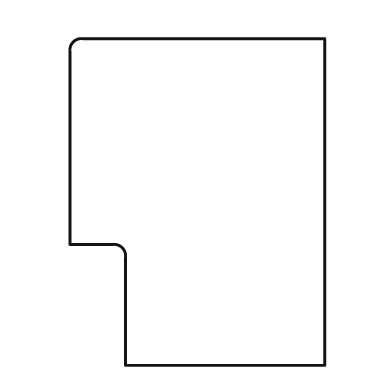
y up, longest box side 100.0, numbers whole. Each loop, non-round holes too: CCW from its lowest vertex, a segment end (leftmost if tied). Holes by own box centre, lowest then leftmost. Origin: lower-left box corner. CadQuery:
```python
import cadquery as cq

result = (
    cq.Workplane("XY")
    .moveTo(17.0, 0.0)
    .lineTo(78.0, 0.0)
    .lineTo(78.0, 100.0)
    .lineTo(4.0, 100.0)
    .threePointArc((1.0, 99.0), (0.0, 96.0))
    .lineTo(0.0, 37.0)
    .lineTo(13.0, 37.0)
    .threePointArc((16.0, 36.0), (17.0, 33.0))
    .close()
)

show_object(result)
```